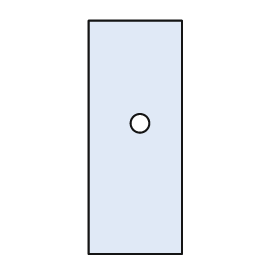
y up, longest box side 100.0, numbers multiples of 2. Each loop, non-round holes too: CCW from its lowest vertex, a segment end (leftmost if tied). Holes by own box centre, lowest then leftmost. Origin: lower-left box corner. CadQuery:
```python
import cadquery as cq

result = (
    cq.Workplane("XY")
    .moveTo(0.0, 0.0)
    .lineTo(40.0, 0.0)
    .lineTo(40.0, 100.0)
    .lineTo(0.0, 100.0)
    .close()
    .moveTo(22.0, 56.0)
    .circle(4.0)
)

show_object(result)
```